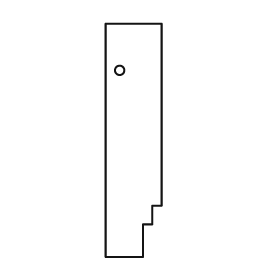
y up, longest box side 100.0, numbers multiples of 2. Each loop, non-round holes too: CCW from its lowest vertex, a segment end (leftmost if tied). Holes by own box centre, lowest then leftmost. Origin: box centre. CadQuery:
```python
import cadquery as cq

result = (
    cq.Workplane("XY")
    .moveTo(-12.0, -50.0)
    .lineTo(4.0, -50.0)
    .lineTo(4.0, -36.0)
    .lineTo(8.0, -36.0)
    .lineTo(8.0, -28.0)
    .lineTo(12.0, -28.0)
    .lineTo(12.0, 50.0)
    .lineTo(-12.0, 50.0)
    .close()
    .moveTo(-6.0, 30.0)
    .circle(2.0)
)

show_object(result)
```